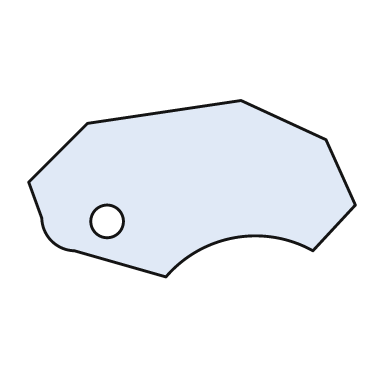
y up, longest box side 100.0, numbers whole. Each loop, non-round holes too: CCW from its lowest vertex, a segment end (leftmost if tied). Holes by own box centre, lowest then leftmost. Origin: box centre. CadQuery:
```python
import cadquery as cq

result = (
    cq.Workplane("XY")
    .moveTo(-8.0, -27.0)
    .threePointArc((13.0, -15.0), (37.0, -19.0))
    .lineTo(50.0, -5.0)
    .lineTo(41.0, 15.0)
    .lineTo(15.0, 27.0)
    .lineTo(-32.0, 20.0)
    .lineTo(-50.0, 2.0)
    .lineTo(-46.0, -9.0)
    .threePointArc((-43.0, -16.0), (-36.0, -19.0))
    .close()
    .moveTo(-26.0, -10.0)
    .circle(5.0)
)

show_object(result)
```